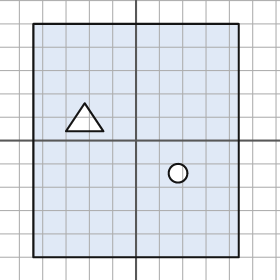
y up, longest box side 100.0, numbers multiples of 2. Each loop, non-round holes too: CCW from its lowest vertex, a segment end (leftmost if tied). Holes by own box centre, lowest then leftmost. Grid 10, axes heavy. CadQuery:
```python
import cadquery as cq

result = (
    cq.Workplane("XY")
    .moveTo(-44.0, -50.0)
    .lineTo(44.0, -50.0)
    .lineTo(44.0, 50.0)
    .lineTo(-44.0, 50.0)
    .close()
    .moveTo(18.0, -14.0)
    .circle(4.0)
    .moveTo(-30.0, 4.0)
    .lineTo(-14.0, 4.0)
    .lineTo(-22.0, 16.0)
    .close()
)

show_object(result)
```